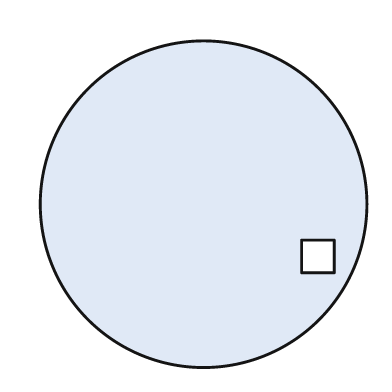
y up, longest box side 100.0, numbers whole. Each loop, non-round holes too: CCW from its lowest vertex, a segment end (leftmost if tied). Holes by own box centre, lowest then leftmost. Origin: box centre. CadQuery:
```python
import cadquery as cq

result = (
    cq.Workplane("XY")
    .moveTo(0.0, 0.0)
    .circle(50.0)
    .moveTo(30.0, -21.0)
    .lineTo(40.0, -21.0)
    .lineTo(40.0, -11.0)
    .lineTo(30.0, -11.0)
    .close()
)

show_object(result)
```